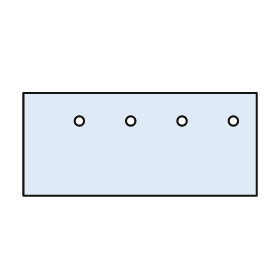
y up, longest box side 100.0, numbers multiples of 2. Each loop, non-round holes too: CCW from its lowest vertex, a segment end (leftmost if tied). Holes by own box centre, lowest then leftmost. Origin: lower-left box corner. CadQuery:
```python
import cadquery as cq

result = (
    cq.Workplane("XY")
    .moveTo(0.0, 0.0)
    .lineTo(100.0, 0.0)
    .lineTo(100.0, 44.0)
    .lineTo(0.0, 44.0)
    .close()
    .moveTo(24.0, 32.0)
    .circle(2.0)
    .moveTo(46.0, 32.0)
    .circle(2.0)
    .moveTo(68.0, 32.0)
    .circle(2.0)
    .moveTo(90.0, 32.0)
    .circle(2.0)
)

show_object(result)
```